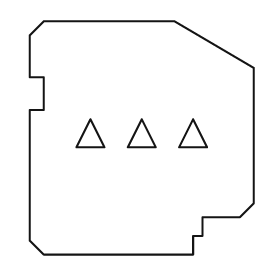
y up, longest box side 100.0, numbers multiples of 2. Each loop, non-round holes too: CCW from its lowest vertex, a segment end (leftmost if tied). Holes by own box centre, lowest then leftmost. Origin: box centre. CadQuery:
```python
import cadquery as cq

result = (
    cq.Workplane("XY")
    .moveTo(-42.0, -50.0)
    .lineTo(22.0, -50.0)
    .lineTo(22.0, -42.0)
    .lineTo(26.0, -42.0)
    .lineTo(26.0, -34.0)
    .lineTo(42.0, -34.0)
    .lineTo(48.0, -28.0)
    .lineTo(48.0, 30.0)
    .lineTo(14.0, 50.0)
    .lineTo(-42.0, 50.0)
    .lineTo(-48.0, 44.0)
    .lineTo(-48.0, 26.0)
    .lineTo(-42.0, 26.0)
    .lineTo(-42.0, 12.0)
    .lineTo(-48.0, 12.0)
    .lineTo(-48.0, -44.0)
    .close()
    .moveTo(-28.0, -4.0)
    .lineTo(-16.0, -4.0)
    .lineTo(-22.0, 8.0)
    .close()
    .moveTo(-6.0, -4.0)
    .lineTo(6.0, -4.0)
    .lineTo(0.0, 8.0)
    .close()
    .moveTo(16.0, -4.0)
    .lineTo(28.0, -4.0)
    .lineTo(22.0, 8.0)
    .close()
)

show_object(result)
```